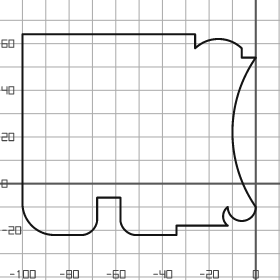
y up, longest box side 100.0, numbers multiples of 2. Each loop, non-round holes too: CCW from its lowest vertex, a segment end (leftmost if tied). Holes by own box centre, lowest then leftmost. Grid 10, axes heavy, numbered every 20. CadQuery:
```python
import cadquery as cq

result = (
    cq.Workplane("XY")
    .moveTo(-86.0, -22.0)
    .lineTo(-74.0, -22.0)
    .threePointArc((-70.0, -20.0), (-68.0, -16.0))
    .lineTo(-68.0, -6.0)
    .lineTo(-58.0, -6.0)
    .lineTo(-58.0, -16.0)
    .threePointArc((-56.0, -20.0), (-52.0, -22.0))
    .lineTo(-34.0, -22.0)
    .lineTo(-34.0, -18.0)
    .lineTo(-12.0, -18.0)
    .threePointArc((-14.0, -14.0), (-12.0, -10.0))
    .threePointArc((-6.0, -16.0), (0.0, -10.0))
    .threePointArc((-10.0, 22.0), (0.0, 54.0))
    .lineTo(-6.0, 54.0)
    .lineTo(-6.0, 58.0)
    .threePointArc((-16.0, 62.0), (-26.0, 58.0))
    .lineTo(-26.0, 64.0)
    .lineTo(-100.0, 64.0)
    .lineTo(-100.0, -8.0)
    .threePointArc((-96.0, -18.0), (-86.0, -22.0))
    .close()
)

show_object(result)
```